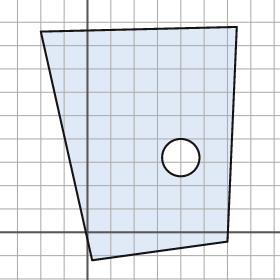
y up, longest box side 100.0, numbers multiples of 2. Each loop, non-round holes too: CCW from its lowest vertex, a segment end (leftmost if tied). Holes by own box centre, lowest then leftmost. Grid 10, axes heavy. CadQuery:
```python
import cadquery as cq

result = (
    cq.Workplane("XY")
    .moveTo(2.0, -12.0)
    .lineTo(60.0, -4.0)
    .lineTo(64.0, 88.0)
    .lineTo(-20.0, 86.0)
    .close()
    .moveTo(40.0, 32.0)
    .circle(8.0)
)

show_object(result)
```